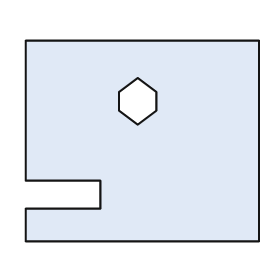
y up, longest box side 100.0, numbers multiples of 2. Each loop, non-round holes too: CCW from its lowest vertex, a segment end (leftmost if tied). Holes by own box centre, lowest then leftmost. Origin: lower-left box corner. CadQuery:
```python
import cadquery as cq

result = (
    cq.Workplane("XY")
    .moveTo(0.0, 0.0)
    .lineTo(100.0, 0.0)
    .lineTo(100.0, 86.0)
    .lineTo(0.0, 86.0)
    .lineTo(0.0, 26.0)
    .lineTo(32.0, 26.0)
    .lineTo(32.0, 14.0)
    .lineTo(0.0, 14.0)
    .close()
    .moveTo(48.0, 50.0)
    .lineTo(56.0, 56.0)
    .lineTo(56.0, 64.0)
    .lineTo(48.0, 70.0)
    .lineTo(40.0, 64.0)
    .lineTo(40.0, 56.0)
    .close()
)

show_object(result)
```